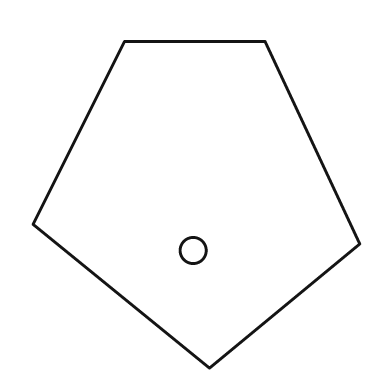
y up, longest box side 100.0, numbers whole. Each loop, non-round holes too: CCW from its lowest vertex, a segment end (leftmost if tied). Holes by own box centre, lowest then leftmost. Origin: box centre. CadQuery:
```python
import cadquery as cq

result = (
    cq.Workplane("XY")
    .moveTo(4.0, -50.0)
    .lineTo(50.0, -12.0)
    .lineTo(21.0, 50.0)
    .lineTo(-22.0, 50.0)
    .lineTo(-50.0, -6.0)
    .close()
    .moveTo(-1.0, -14.0)
    .circle(4.0)
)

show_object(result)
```